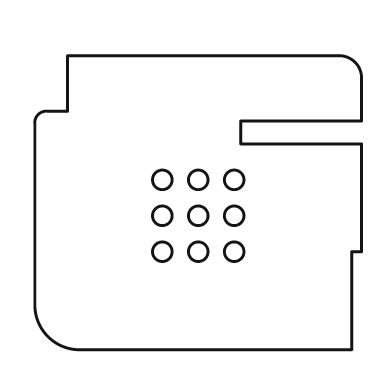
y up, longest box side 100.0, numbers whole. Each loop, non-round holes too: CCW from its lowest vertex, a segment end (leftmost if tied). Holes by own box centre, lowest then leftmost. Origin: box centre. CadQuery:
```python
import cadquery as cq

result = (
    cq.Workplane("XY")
    .moveTo(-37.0, -45.0)
    .lineTo(47.0, -45.0)
    .lineTo(47.0, -15.0)
    .lineTo(50.0, -15.0)
    .lineTo(50.0, 18.0)
    .lineTo(13.0, 18.0)
    .lineTo(13.0, 25.0)
    .lineTo(50.0, 25.0)
    .lineTo(50.0, 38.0)
    .threePointArc((48.0, 43.0), (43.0, 45.0))
    .lineTo(-40.0, 45.0)
    .lineTo(-40.0, 28.0)
    .lineTo(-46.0, 28.0)
    .threePointArc((-49.0, 27.0), (-50.0, 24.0))
    .lineTo(-50.0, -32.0)
    .threePointArc((-46.0, -41.0), (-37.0, -45.0))
    .close()
    .moveTo(-11.0, -15.0)
    .circle(3.0)
    .moveTo(0.0, -15.0)
    .circle(3.0)
    .moveTo(11.0, -15.0)
    .circle(3.0)
    .moveTo(-11.0, -4.0)
    .circle(3.0)
    .moveTo(0.0, -4.0)
    .circle(3.0)
    .moveTo(11.0, -4.0)
    .circle(3.0)
    .moveTo(-11.0, 7.0)
    .circle(3.0)
    .moveTo(0.0, 7.0)
    .circle(3.0)
    .moveTo(11.0, 7.0)
    .circle(3.0)
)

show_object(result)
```